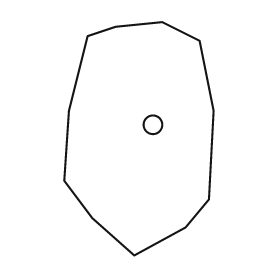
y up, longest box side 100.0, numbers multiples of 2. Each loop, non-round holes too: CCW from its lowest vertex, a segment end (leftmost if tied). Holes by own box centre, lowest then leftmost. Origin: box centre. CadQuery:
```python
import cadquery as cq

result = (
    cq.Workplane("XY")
    .moveTo(-2.0, -50.0)
    .lineTo(20.0, -38.0)
    .lineTo(30.0, -26.0)
    .lineTo(32.0, 12.0)
    .lineTo(26.0, 42.0)
    .lineTo(10.0, 50.0)
    .lineTo(-10.0, 48.0)
    .lineTo(-22.0, 44.0)
    .lineTo(-30.0, 12.0)
    .lineTo(-32.0, -18.0)
    .lineTo(-20.0, -34.0)
    .close()
    .moveTo(6.0, 6.0)
    .circle(4.0)
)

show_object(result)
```